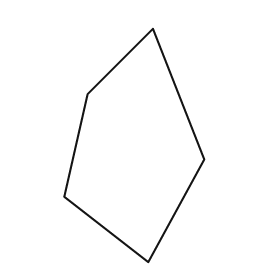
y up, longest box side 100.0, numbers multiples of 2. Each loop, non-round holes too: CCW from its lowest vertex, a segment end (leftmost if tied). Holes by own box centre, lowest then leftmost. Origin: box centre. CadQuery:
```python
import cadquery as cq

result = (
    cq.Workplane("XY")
    .moveTo(6.0, -50.0)
    .lineTo(30.0, -6.0)
    .lineTo(8.0, 50.0)
    .lineTo(-20.0, 22.0)
    .lineTo(-30.0, -22.0)
    .close()
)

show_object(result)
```